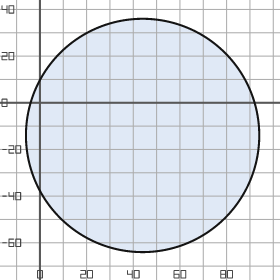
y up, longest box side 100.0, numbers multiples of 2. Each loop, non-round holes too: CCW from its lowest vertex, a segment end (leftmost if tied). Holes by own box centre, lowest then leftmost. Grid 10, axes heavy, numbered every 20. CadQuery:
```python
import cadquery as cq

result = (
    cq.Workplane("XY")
    .moveTo(44.0, -14.0)
    .circle(50.0)
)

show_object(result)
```